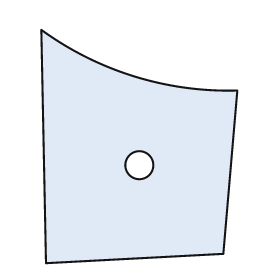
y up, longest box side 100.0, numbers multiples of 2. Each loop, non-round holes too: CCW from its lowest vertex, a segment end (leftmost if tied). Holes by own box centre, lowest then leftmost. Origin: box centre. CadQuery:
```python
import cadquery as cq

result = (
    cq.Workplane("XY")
    .moveTo(-40.0, -50.0)
    .lineTo(36.0, -46.0)
    .lineTo(42.0, 24.0)
    .threePointArc((-2.0, 30.0), (-42.0, 50.0))
    .close()
    .moveTo(0.0, -8.0)
    .circle(6.0)
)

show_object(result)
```